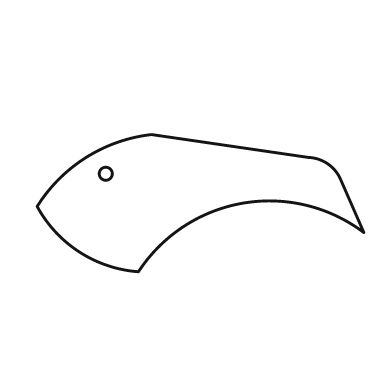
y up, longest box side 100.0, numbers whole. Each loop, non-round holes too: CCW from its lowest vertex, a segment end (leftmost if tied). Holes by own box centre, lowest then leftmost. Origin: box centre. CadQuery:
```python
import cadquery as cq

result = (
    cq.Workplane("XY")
    .moveTo(-19.0, -21.0)
    .threePointArc((13.0, 0.0), (50.0, -9.0))
    .lineTo(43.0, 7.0)
    .threePointArc((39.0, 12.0), (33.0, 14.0))
    .lineTo(-15.0, 21.0)
    .threePointArc((-35.0, 14.0), (-50.0, -1.0))
    .threePointArc((-37.0, -15.0), (-19.0, -21.0))
    .close()
    .moveTo(-29.0, 9.0)
    .circle(2.0)
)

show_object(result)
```